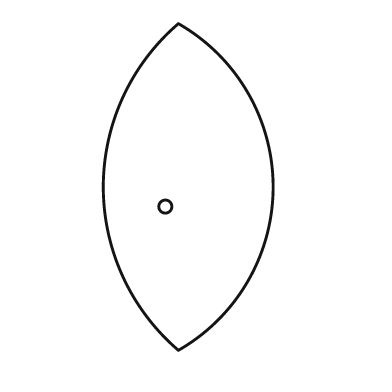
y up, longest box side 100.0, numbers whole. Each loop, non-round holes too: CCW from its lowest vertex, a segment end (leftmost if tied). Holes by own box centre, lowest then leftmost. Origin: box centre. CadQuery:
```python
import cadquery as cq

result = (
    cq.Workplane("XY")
    .moveTo(-3.0, -50.0)
    .threePointArc((26.0, 0.0), (-3.0, 50.0))
    .threePointArc((-26.0, 0.0), (-3.0, -50.0))
    .close()
    .moveTo(-7.0, -6.0)
    .circle(2.0)
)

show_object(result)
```